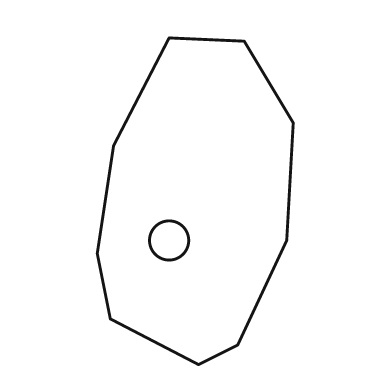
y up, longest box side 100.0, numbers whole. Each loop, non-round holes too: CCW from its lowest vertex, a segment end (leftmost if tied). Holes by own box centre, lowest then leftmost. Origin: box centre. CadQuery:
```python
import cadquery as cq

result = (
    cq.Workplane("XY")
    .moveTo(1.0, -50.0)
    .lineTo(13.0, -44.0)
    .lineTo(28.0, -12.0)
    .lineTo(30.0, 24.0)
    .lineTo(15.0, 49.0)
    .lineTo(-8.0, 50.0)
    .lineTo(-25.0, 17.0)
    .lineTo(-30.0, -16.0)
    .lineTo(-26.0, -36.0)
    .close()
    .moveTo(-8.0, -12.0)
    .circle(6.0)
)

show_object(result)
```